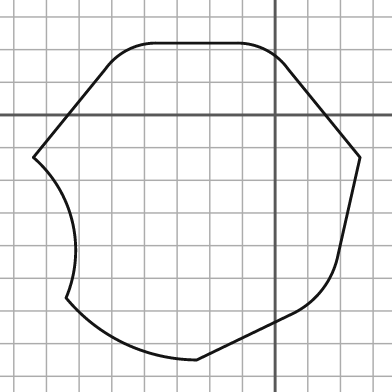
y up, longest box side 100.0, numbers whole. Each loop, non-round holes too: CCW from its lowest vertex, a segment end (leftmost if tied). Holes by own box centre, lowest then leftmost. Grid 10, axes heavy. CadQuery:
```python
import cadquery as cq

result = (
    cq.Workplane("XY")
    .moveTo(-24.0, -75.0)
    .lineTo(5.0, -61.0)
    .threePointArc((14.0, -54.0), (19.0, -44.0))
    .lineTo(26.0, -13.0)
    .lineTo(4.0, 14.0)
    .threePointArc((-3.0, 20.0), (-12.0, 22.0))
    .lineTo(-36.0, 22.0)
    .threePointArc((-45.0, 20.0), (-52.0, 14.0))
    .lineTo(-74.0, -13.0)
    .threePointArc((-62.0, -33.0), (-64.0, -56.0))
    .threePointArc((-46.0, -70.0), (-24.0, -75.0))
    .close()
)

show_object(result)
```